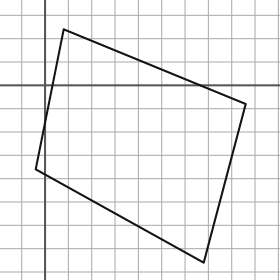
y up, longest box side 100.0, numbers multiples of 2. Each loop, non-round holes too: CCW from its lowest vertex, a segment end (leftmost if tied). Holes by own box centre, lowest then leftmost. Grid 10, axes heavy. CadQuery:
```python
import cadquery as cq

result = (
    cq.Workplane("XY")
    .moveTo(68.0, -76.0)
    .lineTo(86.0, -8.0)
    .lineTo(8.0, 24.0)
    .lineTo(-4.0, -36.0)
    .close()
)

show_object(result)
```